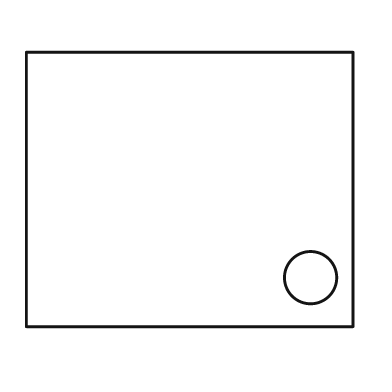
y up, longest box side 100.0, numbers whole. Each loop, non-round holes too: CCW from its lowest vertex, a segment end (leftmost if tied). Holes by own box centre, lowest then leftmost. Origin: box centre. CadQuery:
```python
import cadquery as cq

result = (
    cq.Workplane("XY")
    .moveTo(-50.0, -42.0)
    .lineTo(50.0, -42.0)
    .lineTo(50.0, 42.0)
    .lineTo(-50.0, 42.0)
    .close()
    .moveTo(37.0, -27.0)
    .circle(8.0)
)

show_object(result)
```